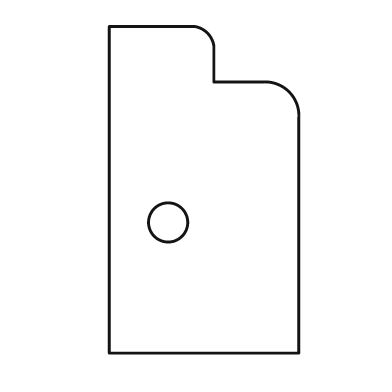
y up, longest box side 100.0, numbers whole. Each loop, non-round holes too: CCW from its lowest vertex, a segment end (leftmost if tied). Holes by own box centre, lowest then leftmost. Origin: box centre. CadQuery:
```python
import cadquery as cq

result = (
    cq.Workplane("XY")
    .moveTo(-29.0, -50.0)
    .lineTo(29.0, -50.0)
    .lineTo(29.0, 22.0)
    .threePointArc((26.0, 30.0), (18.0, 33.0))
    .lineTo(3.0, 33.0)
    .lineTo(3.0, 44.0)
    .threePointArc((1.0, 48.0), (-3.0, 50.0))
    .lineTo(-29.0, 50.0)
    .close()
    .moveTo(-11.0, -10.0)
    .circle(6.0)
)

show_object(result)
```